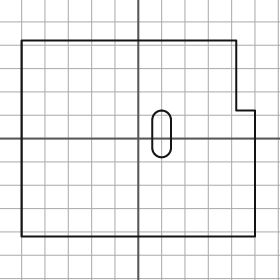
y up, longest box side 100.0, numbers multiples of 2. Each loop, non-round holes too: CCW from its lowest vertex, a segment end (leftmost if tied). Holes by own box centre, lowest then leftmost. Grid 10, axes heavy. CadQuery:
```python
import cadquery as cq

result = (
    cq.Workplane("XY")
    .moveTo(-50.0, -42.0)
    .lineTo(50.0, -42.0)
    .lineTo(50.0, 12.0)
    .lineTo(42.0, 12.0)
    .lineTo(42.0, 42.0)
    .lineTo(-50.0, 42.0)
    .close()
    .moveTo(6.0, -4.0)
    .threePointArc((10.0, -8.0), (14.0, -4.0))
    .lineTo(14.0, 8.0)
    .threePointArc((10.0, 12.0), (6.0, 8.0))
    .close()
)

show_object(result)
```